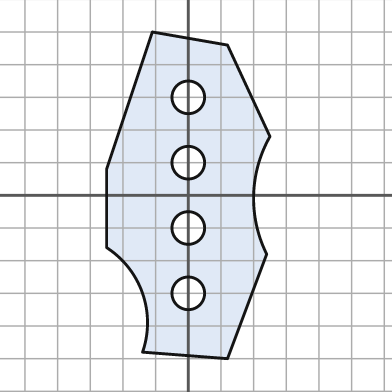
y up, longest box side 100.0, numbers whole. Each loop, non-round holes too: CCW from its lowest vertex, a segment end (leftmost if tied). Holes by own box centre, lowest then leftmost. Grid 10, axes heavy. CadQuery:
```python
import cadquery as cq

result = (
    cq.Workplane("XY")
    .moveTo(12.0, -50.0)
    .lineTo(24.0, -18.0)
    .threePointArc((20.0, 0.0), (25.0, 18.0))
    .lineTo(12.0, 46.0)
    .lineTo(-11.0, 50.0)
    .lineTo(-25.0, 8.0)
    .lineTo(-25.0, -16.0)
    .threePointArc((-14.0, -30.0), (-14.0, -48.0))
    .close()
    .moveTo(0.0, -30.0)
    .circle(5.0)
    .moveTo(0.0, -10.0)
    .circle(5.0)
    .moveTo(0.0, 10.0)
    .circle(5.0)
    .moveTo(0.0, 30.0)
    .circle(5.0)
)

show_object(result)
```